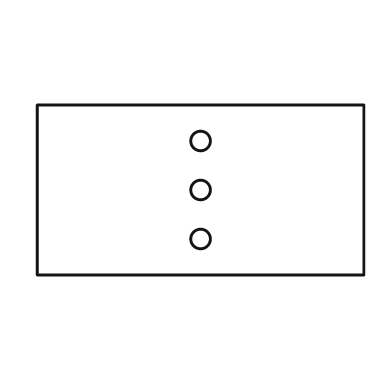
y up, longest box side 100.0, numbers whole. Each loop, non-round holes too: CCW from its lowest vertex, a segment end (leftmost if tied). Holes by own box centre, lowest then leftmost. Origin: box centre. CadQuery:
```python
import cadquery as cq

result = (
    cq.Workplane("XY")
    .moveTo(-50.0, -26.0)
    .lineTo(50.0, -26.0)
    .lineTo(50.0, 26.0)
    .lineTo(-50.0, 26.0)
    .close()
    .moveTo(0.0, -15.0)
    .circle(3.0)
    .moveTo(0.0, 0.0)
    .circle(3.0)
    .moveTo(0.0, 15.0)
    .circle(3.0)
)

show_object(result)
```